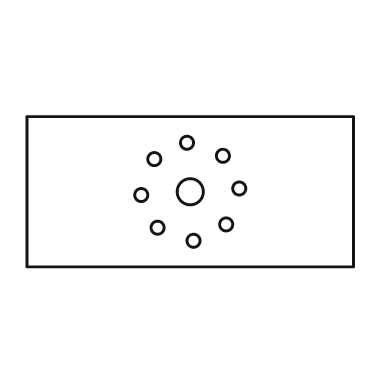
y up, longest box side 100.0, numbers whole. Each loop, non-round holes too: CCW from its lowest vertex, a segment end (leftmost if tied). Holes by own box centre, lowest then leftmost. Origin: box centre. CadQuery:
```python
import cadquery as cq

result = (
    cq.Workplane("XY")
    .moveTo(-50.0, -23.0)
    .lineTo(50.0, -23.0)
    .lineTo(50.0, 23.0)
    .lineTo(-50.0, 23.0)
    .close()
    .moveTo(1.0, -15.0)
    .circle(2.0)
    .moveTo(-10.0, -11.0)
    .circle(2.0)
    .moveTo(11.0, -10.0)
    .circle(2.0)
    .moveTo(-15.0, -1.0)
    .circle(2.0)
    .moveTo(0.0, 0.0)
    .circle(4.0)
    .moveTo(15.0, 1.0)
    .circle(2.0)
    .moveTo(-11.0, 10.0)
    .circle(2.0)
    .moveTo(10.0, 11.0)
    .circle(2.0)
    .moveTo(-1.0, 15.0)
    .circle(2.0)
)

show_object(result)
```